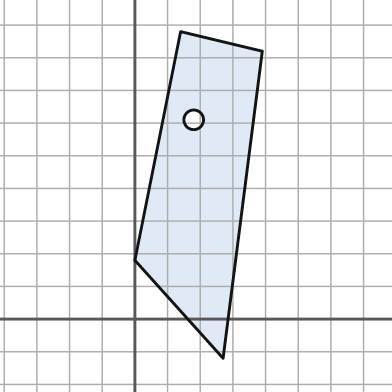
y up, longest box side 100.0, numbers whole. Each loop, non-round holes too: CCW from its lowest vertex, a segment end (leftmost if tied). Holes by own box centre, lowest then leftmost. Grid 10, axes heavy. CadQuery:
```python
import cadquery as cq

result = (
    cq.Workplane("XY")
    .moveTo(27.0, -12.0)
    .lineTo(39.0, 82.0)
    .lineTo(14.0, 88.0)
    .lineTo(0.0, 18.0)
    .close()
    .moveTo(18.0, 61.0)
    .circle(3.0)
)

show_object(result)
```